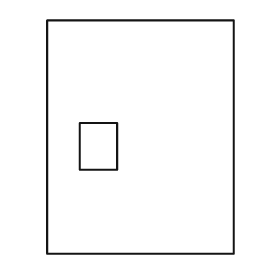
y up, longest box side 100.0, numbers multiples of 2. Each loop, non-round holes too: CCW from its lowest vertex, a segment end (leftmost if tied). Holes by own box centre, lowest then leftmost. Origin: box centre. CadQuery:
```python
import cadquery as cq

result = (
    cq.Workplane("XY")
    .moveTo(-40.0, -50.0)
    .lineTo(40.0, -50.0)
    .lineTo(40.0, 50.0)
    .lineTo(-40.0, 50.0)
    .close()
    .moveTo(-26.0, -14.0)
    .lineTo(-10.0, -14.0)
    .lineTo(-10.0, 6.0)
    .lineTo(-26.0, 6.0)
    .close()
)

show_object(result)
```